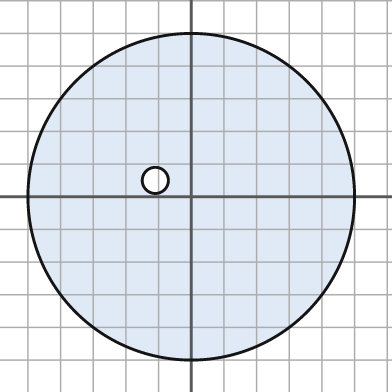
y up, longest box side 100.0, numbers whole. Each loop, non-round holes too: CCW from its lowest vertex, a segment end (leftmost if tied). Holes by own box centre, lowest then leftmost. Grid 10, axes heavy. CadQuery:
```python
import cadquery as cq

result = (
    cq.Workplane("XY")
    .moveTo(0.0, 0.0)
    .circle(50.0)
    .moveTo(-11.0, 5.0)
    .circle(4.0)
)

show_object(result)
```